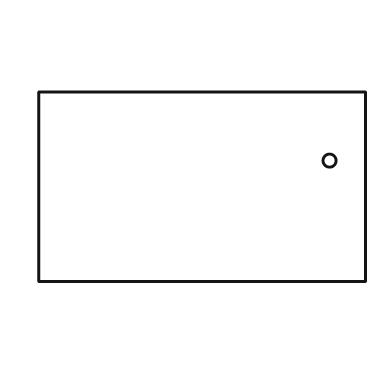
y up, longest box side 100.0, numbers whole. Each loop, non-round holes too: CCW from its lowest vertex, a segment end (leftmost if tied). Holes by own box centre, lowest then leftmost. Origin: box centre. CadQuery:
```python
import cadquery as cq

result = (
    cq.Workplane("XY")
    .moveTo(-50.0, -29.0)
    .lineTo(50.0, -29.0)
    .lineTo(50.0, 29.0)
    .lineTo(-50.0, 29.0)
    .close()
    .moveTo(39.0, 8.0)
    .circle(2.0)
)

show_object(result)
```